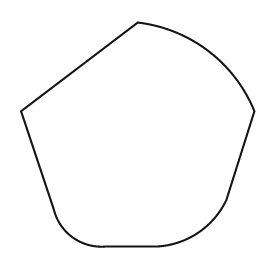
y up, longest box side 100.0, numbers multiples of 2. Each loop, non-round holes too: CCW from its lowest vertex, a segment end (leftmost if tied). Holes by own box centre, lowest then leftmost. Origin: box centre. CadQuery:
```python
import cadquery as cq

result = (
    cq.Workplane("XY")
    .moveTo(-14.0, -48.0)
    .lineTo(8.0, -48.0)
    .threePointArc((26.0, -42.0), (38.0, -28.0))
    .lineTo(50.0, 10.0)
    .threePointArc((30.0, 36.0), (0.0, 48.0))
    .lineTo(-50.0, 10.0)
    .lineTo(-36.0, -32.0)
    .threePointArc((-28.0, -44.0), (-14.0, -48.0))
    .close()
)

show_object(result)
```